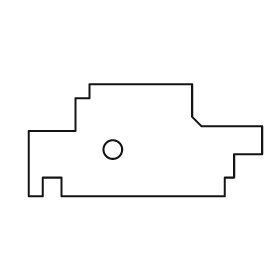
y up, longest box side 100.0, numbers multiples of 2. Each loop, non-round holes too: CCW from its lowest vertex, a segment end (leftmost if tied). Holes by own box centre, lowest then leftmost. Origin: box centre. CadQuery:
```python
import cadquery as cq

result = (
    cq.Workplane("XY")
    .moveTo(-50.0, -24.0)
    .lineTo(-44.0, -24.0)
    .lineTo(-44.0, -16.0)
    .lineTo(-36.0, -16.0)
    .lineTo(-36.0, -24.0)
    .lineTo(34.0, -24.0)
    .lineTo(34.0, -16.0)
    .lineTo(38.0, -16.0)
    .lineTo(38.0, -6.0)
    .lineTo(50.0, -6.0)
    .lineTo(50.0, 6.0)
    .lineTo(24.0, 6.0)
    .lineTo(20.0, 10.0)
    .lineTo(20.0, 24.0)
    .lineTo(-24.0, 24.0)
    .lineTo(-24.0, 18.0)
    .lineTo(-30.0, 18.0)
    .lineTo(-30.0, 4.0)
    .lineTo(-50.0, 4.0)
    .close()
    .moveTo(-14.0, -4.0)
    .circle(4.0)
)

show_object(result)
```